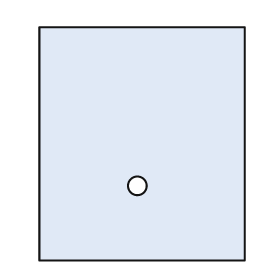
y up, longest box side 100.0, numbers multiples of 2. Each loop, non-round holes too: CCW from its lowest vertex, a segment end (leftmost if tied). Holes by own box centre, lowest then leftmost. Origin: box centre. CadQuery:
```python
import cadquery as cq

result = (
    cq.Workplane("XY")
    .moveTo(-44.0, -50.0)
    .lineTo(44.0, -50.0)
    .lineTo(44.0, 50.0)
    .lineTo(-44.0, 50.0)
    .close()
    .moveTo(-2.0, -18.0)
    .circle(4.0)
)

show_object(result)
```